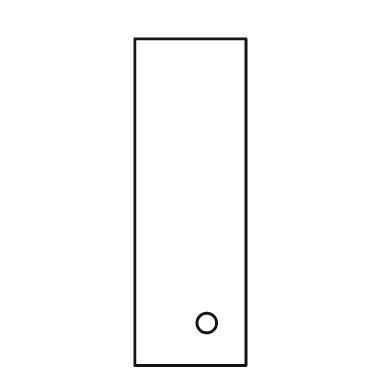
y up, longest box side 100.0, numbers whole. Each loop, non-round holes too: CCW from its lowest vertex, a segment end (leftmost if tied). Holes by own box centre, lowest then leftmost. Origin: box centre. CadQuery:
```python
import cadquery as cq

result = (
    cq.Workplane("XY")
    .moveTo(-17.0, -50.0)
    .lineTo(17.0, -50.0)
    .lineTo(17.0, 50.0)
    .lineTo(-17.0, 50.0)
    .close()
    .moveTo(5.0, -37.0)
    .circle(3.0)
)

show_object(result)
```